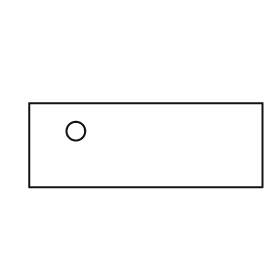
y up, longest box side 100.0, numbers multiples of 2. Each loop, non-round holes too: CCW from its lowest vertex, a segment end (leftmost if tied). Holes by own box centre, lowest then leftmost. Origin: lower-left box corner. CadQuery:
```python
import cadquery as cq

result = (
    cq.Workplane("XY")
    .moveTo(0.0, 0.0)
    .lineTo(100.0, 0.0)
    .lineTo(100.0, 36.0)
    .lineTo(0.0, 36.0)
    .close()
    .moveTo(20.0, 24.0)
    .circle(4.0)
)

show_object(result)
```